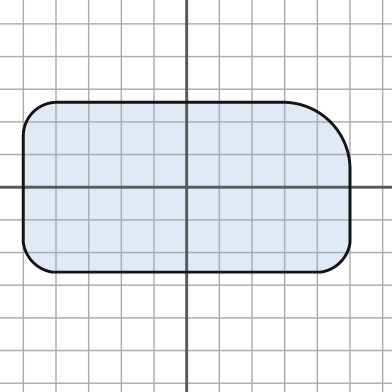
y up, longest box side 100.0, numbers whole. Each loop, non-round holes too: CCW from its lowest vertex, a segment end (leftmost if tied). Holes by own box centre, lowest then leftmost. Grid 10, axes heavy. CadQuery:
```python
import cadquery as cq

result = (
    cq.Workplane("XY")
    .moveTo(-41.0, -26.0)
    .lineTo(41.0, -26.0)
    .threePointArc((47.0, -23.0), (50.0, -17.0))
    .lineTo(50.0, 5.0)
    .threePointArc((44.0, 20.0), (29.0, 26.0))
    .lineTo(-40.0, 26.0)
    .threePointArc((-47.0, 23.0), (-50.0, 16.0))
    .lineTo(-50.0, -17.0)
    .threePointArc((-47.0, -23.0), (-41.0, -26.0))
    .close()
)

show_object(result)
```